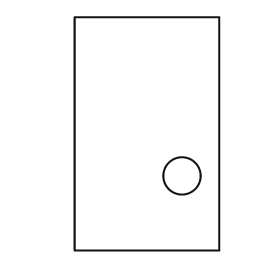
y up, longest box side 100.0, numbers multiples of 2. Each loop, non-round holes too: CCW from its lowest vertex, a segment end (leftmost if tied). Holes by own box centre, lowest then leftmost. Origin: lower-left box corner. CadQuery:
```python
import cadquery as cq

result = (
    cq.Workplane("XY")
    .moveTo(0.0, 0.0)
    .lineTo(62.0, 0.0)
    .lineTo(62.0, 100.0)
    .lineTo(0.0, 100.0)
    .close()
    .moveTo(46.0, 32.0)
    .circle(8.0)
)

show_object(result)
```